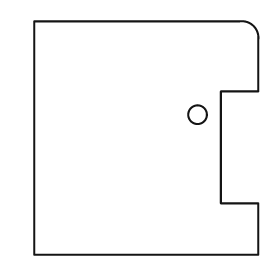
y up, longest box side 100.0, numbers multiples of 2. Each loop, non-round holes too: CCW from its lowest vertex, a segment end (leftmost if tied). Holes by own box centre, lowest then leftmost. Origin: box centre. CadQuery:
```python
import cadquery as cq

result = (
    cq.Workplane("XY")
    .moveTo(-48.0, -50.0)
    .lineTo(48.0, -50.0)
    .lineTo(48.0, -28.0)
    .lineTo(32.0, -28.0)
    .lineTo(32.0, 20.0)
    .lineTo(48.0, 20.0)
    .lineTo(48.0, 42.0)
    .threePointArc((46.0, 48.0), (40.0, 50.0))
    .lineTo(-48.0, 50.0)
    .close()
    .moveTo(22.0, 10.0)
    .circle(4.0)
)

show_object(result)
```